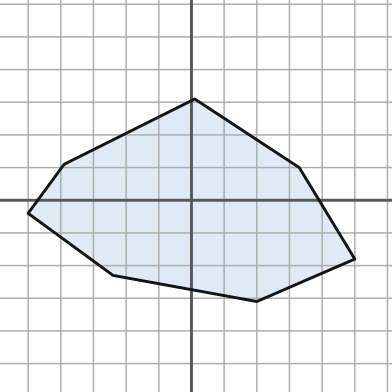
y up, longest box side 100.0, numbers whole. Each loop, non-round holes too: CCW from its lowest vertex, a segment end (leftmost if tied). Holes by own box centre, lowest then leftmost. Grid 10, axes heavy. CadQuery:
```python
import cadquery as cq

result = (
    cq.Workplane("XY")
    .moveTo(20.0, -31.0)
    .lineTo(50.0, -18.0)
    .lineTo(33.0, 10.0)
    .lineTo(1.0, 31.0)
    .lineTo(-39.0, 11.0)
    .lineTo(-50.0, -4.0)
    .lineTo(-24.0, -23.0)
    .close()
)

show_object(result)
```